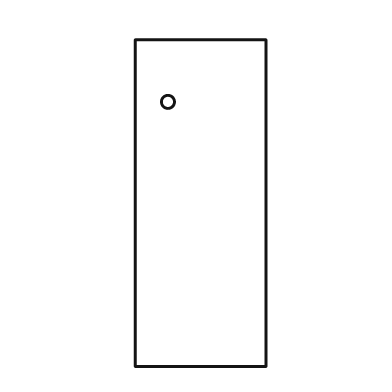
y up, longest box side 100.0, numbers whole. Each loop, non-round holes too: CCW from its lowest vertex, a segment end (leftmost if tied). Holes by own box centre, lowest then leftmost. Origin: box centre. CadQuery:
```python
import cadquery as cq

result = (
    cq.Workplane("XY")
    .moveTo(-20.0, -50.0)
    .lineTo(20.0, -50.0)
    .lineTo(20.0, 50.0)
    .lineTo(-20.0, 50.0)
    .close()
    .moveTo(-10.0, 31.0)
    .circle(2.0)
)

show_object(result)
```